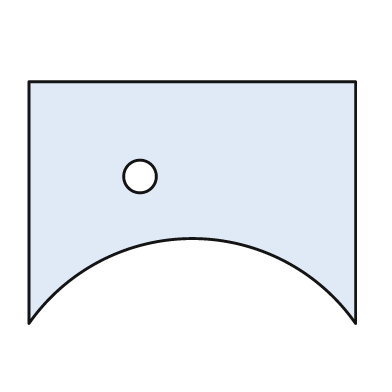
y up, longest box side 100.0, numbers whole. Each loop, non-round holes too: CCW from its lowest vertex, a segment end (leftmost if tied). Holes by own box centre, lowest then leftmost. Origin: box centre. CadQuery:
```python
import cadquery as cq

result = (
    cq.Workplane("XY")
    .moveTo(-50.0, -37.0)
    .threePointArc((0.0, -11.0), (50.0, -37.0))
    .lineTo(50.0, 37.0)
    .lineTo(-50.0, 37.0)
    .close()
    .moveTo(-16.0, 8.0)
    .circle(5.0)
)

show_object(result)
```